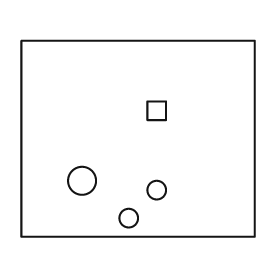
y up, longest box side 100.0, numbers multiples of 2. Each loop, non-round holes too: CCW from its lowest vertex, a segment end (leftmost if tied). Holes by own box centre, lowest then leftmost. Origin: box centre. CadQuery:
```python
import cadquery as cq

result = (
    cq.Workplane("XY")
    .moveTo(-50.0, -42.0)
    .lineTo(50.0, -42.0)
    .lineTo(50.0, 42.0)
    .lineTo(-50.0, 42.0)
    .close()
    .moveTo(-4.0, -34.0)
    .circle(4.0)
    .moveTo(8.0, -22.0)
    .circle(4.0)
    .moveTo(-24.0, -18.0)
    .circle(6.0)
    .moveTo(4.0, 8.0)
    .lineTo(12.0, 8.0)
    .lineTo(12.0, 16.0)
    .lineTo(4.0, 16.0)
    .close()
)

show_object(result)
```